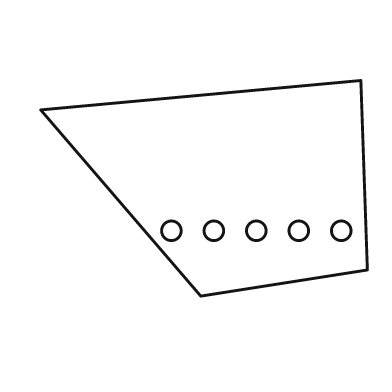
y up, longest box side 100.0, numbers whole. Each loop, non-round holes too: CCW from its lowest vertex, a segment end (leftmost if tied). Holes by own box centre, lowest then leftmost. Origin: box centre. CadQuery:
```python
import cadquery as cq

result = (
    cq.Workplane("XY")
    .moveTo(-1.0, -33.0)
    .lineTo(50.0, -25.0)
    .lineTo(48.0, 33.0)
    .lineTo(-50.0, 24.0)
    .close()
    .moveTo(-10.0, -13.0)
    .circle(3.0)
    .moveTo(3.0, -13.0)
    .circle(3.0)
    .moveTo(16.0, -13.0)
    .circle(3.0)
    .moveTo(29.0, -13.0)
    .circle(3.0)
    .moveTo(42.0, -13.0)
    .circle(3.0)
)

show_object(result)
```